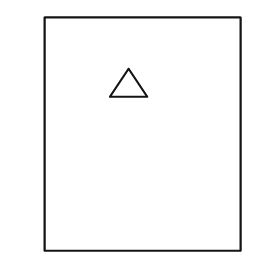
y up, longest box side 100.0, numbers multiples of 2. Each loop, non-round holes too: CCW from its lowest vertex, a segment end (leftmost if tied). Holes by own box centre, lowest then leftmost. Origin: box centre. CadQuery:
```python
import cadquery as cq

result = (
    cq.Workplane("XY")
    .moveTo(-42.0, -50.0)
    .lineTo(42.0, -50.0)
    .lineTo(42.0, 50.0)
    .lineTo(-42.0, 50.0)
    .close()
    .moveTo(-14.0, 16.0)
    .lineTo(2.0, 16.0)
    .lineTo(-6.0, 28.0)
    .close()
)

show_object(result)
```